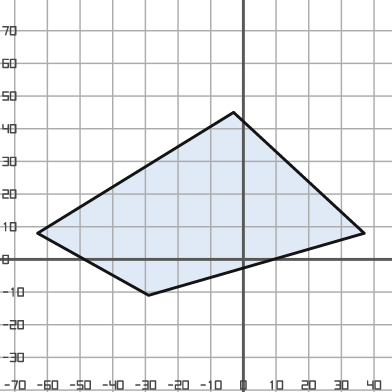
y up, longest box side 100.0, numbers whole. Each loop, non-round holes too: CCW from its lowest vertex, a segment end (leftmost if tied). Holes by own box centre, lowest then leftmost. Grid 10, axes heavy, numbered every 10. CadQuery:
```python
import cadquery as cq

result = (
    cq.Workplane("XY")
    .moveTo(-29.0, -11.0)
    .lineTo(37.0, 8.0)
    .lineTo(-3.0, 45.0)
    .lineTo(-63.0, 8.0)
    .close()
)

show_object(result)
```